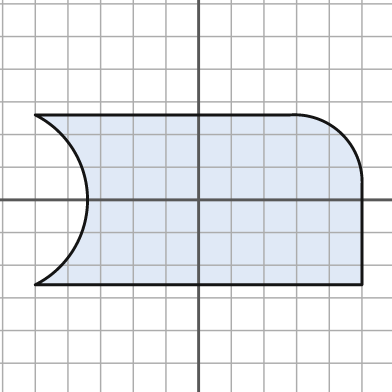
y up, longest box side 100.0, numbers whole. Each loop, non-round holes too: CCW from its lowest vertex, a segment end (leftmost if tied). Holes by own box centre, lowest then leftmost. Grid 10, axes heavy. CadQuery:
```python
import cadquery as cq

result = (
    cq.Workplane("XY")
    .moveTo(-50.0, -26.0)
    .lineTo(50.0, -26.0)
    .lineTo(50.0, 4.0)
    .threePointArc((44.0, 20.0), (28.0, 26.0))
    .lineTo(-50.0, 26.0)
    .threePointArc((-34.0, 0.0), (-50.0, -26.0))
    .close()
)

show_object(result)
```